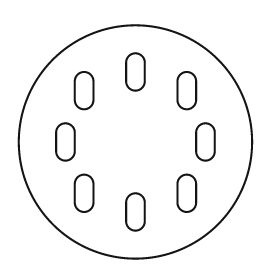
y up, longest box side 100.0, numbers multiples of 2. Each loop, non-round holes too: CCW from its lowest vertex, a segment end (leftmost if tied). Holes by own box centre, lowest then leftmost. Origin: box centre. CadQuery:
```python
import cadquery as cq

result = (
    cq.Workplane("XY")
    .moveTo(0.0, 0.0)
    .circle(50.0)
    .moveTo(-4.0, -34.0)
    .threePointArc((0.0, -38.0), (4.0, -34.0))
    .lineTo(4.0, -26.0)
    .threePointArc((0.0, -22.0), (-4.0, -26.0))
    .close()
    .moveTo(-26.0, -26.0)
    .threePointArc((-22.0, -30.0), (-18.0, -26.0))
    .lineTo(-18.0, -18.0)
    .threePointArc((-22.0, -14.0), (-26.0, -18.0))
    .close()
    .moveTo(18.0, -26.0)
    .threePointArc((22.0, -30.0), (26.0, -26.0))
    .lineTo(26.0, -18.0)
    .threePointArc((22.0, -14.0), (18.0, -18.0))
    .close()
    .moveTo(-34.0, -4.0)
    .threePointArc((-30.0, -8.0), (-26.0, -4.0))
    .lineTo(-26.0, 4.0)
    .threePointArc((-30.0, 8.0), (-34.0, 4.0))
    .close()
    .moveTo(26.0, -4.0)
    .threePointArc((30.0, -8.0), (34.0, -4.0))
    .lineTo(34.0, 4.0)
    .threePointArc((30.0, 8.0), (26.0, 4.0))
    .close()
    .moveTo(-26.0, 18.0)
    .threePointArc((-22.0, 14.0), (-18.0, 18.0))
    .lineTo(-18.0, 26.0)
    .threePointArc((-22.0, 30.0), (-26.0, 26.0))
    .close()
    .moveTo(18.0, 18.0)
    .threePointArc((22.0, 14.0), (26.0, 18.0))
    .lineTo(26.0, 26.0)
    .threePointArc((22.0, 30.0), (18.0, 26.0))
    .close()
    .moveTo(-4.0, 26.0)
    .threePointArc((0.0, 22.0), (4.0, 26.0))
    .lineTo(4.0, 34.0)
    .threePointArc((0.0, 38.0), (-4.0, 34.0))
    .close()
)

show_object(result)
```